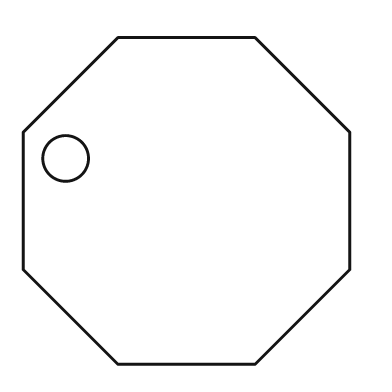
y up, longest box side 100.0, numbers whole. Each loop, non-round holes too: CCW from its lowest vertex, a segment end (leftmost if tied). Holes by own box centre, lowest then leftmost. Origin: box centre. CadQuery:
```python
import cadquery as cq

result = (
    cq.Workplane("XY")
    .moveTo(-21.0, -50.0)
    .lineTo(21.0, -50.0)
    .lineTo(50.0, -21.0)
    .lineTo(50.0, 21.0)
    .lineTo(21.0, 50.0)
    .lineTo(-21.0, 50.0)
    .lineTo(-50.0, 21.0)
    .lineTo(-50.0, -21.0)
    .close()
    .moveTo(-37.0, 13.0)
    .circle(7.0)
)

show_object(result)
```